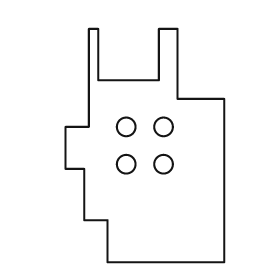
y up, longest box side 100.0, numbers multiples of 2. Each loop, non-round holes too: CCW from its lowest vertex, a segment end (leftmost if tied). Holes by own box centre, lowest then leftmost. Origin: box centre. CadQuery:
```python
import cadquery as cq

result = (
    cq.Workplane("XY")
    .moveTo(-16.0, -50.0)
    .lineTo(34.0, -50.0)
    .lineTo(34.0, 20.0)
    .lineTo(14.0, 20.0)
    .lineTo(14.0, 50.0)
    .lineTo(6.0, 50.0)
    .lineTo(6.0, 28.0)
    .lineTo(-20.0, 28.0)
    .lineTo(-20.0, 50.0)
    .lineTo(-24.0, 50.0)
    .lineTo(-24.0, 8.0)
    .lineTo(-34.0, 8.0)
    .lineTo(-34.0, -10.0)
    .lineTo(-26.0, -10.0)
    .lineTo(-26.0, -32.0)
    .lineTo(-16.0, -32.0)
    .close()
    .moveTo(-8.0, -8.0)
    .circle(4.0)
    .moveTo(8.0, -8.0)
    .circle(4.0)
    .moveTo(-8.0, 8.0)
    .circle(4.0)
    .moveTo(8.0, 8.0)
    .circle(4.0)
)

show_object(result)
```